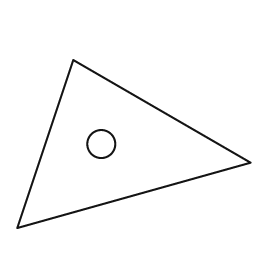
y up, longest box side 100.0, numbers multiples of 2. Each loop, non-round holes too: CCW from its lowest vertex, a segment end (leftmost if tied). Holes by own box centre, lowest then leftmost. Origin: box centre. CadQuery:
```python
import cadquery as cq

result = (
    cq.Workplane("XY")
    .moveTo(-50.0, -36.0)
    .lineTo(50.0, -8.0)
    .lineTo(-26.0, 36.0)
    .close()
    .moveTo(-14.0, 0.0)
    .circle(6.0)
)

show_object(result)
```